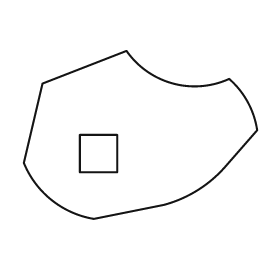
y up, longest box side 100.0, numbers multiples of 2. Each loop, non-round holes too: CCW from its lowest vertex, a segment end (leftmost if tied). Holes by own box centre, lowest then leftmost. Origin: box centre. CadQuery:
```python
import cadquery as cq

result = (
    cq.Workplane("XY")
    .moveTo(-20.0, -36.0)
    .lineTo(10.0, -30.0)
    .threePointArc((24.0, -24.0), (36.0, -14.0))
    .lineTo(50.0, 2.0)
    .threePointArc((46.0, 14.0), (38.0, 24.0))
    .threePointArc((14.0, 22.0), (-6.0, 36.0))
    .lineTo(-42.0, 22.0)
    .lineTo(-50.0, -12.0)
    .threePointArc((-38.0, -28.0), (-20.0, -36.0))
    .close()
    .moveTo(-26.0, -16.0)
    .lineTo(-10.0, -16.0)
    .lineTo(-10.0, 0.0)
    .lineTo(-26.0, 0.0)
    .close()
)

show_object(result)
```